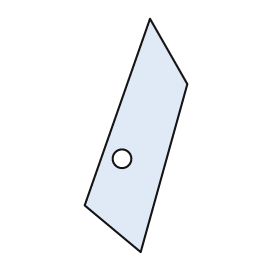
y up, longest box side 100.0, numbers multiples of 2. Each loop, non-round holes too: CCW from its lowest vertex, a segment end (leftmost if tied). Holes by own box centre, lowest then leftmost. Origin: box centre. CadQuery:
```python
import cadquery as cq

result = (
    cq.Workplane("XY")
    .moveTo(2.0, -50.0)
    .lineTo(22.0, 22.0)
    .lineTo(6.0, 50.0)
    .lineTo(-22.0, -30.0)
    .close()
    .moveTo(-6.0, -10.0)
    .circle(4.0)
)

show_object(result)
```